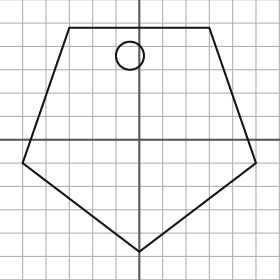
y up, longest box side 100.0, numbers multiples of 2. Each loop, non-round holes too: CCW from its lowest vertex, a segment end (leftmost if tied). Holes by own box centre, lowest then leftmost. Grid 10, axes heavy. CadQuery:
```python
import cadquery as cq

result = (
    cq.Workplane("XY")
    .moveTo(0.0, -48.0)
    .lineTo(50.0, -10.0)
    .lineTo(30.0, 48.0)
    .lineTo(-30.0, 48.0)
    .lineTo(-50.0, -10.0)
    .close()
    .moveTo(-4.0, 36.0)
    .circle(6.0)
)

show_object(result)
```